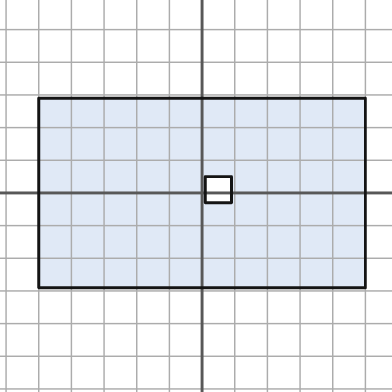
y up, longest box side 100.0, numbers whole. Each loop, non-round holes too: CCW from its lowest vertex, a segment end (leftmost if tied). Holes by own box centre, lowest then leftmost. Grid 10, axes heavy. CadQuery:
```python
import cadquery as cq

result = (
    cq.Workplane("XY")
    .moveTo(-50.0, -29.0)
    .lineTo(50.0, -29.0)
    .lineTo(50.0, 29.0)
    .lineTo(-50.0, 29.0)
    .close()
    .moveTo(1.0, -3.0)
    .lineTo(9.0, -3.0)
    .lineTo(9.0, 5.0)
    .lineTo(1.0, 5.0)
    .close()
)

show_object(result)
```